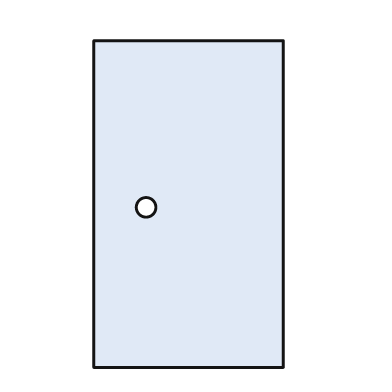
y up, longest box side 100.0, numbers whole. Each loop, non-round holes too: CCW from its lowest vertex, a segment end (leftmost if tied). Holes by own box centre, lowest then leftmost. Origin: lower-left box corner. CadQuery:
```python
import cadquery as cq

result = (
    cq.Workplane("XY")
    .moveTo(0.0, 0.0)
    .lineTo(58.0, 0.0)
    .lineTo(58.0, 100.0)
    .lineTo(0.0, 100.0)
    .close()
    .moveTo(16.0, 49.0)
    .circle(3.0)
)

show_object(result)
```